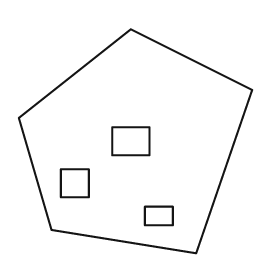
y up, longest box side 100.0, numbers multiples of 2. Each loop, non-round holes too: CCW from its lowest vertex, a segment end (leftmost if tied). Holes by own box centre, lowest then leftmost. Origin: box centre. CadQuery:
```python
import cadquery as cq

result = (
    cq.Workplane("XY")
    .moveTo(26.0, -48.0)
    .lineTo(50.0, 22.0)
    .lineTo(-2.0, 48.0)
    .lineTo(-50.0, 10.0)
    .lineTo(-36.0, -38.0)
    .close()
    .moveTo(4.0, -36.0)
    .lineTo(16.0, -36.0)
    .lineTo(16.0, -28.0)
    .lineTo(4.0, -28.0)
    .close()
    .moveTo(-32.0, -24.0)
    .lineTo(-20.0, -24.0)
    .lineTo(-20.0, -12.0)
    .lineTo(-32.0, -12.0)
    .close()
    .moveTo(-10.0, -6.0)
    .lineTo(6.0, -6.0)
    .lineTo(6.0, 6.0)
    .lineTo(-10.0, 6.0)
    .close()
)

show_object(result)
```